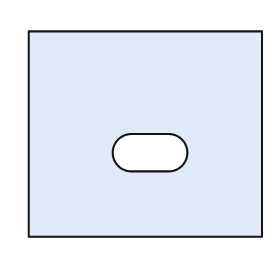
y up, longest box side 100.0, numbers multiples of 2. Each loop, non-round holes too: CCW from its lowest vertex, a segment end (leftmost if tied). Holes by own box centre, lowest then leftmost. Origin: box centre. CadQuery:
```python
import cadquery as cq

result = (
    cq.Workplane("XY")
    .moveTo(-50.0, -44.0)
    .lineTo(50.0, -44.0)
    .lineTo(50.0, 44.0)
    .lineTo(-50.0, 44.0)
    .close()
    .moveTo(-6.0, -16.0)
    .lineTo(10.0, -16.0)
    .threePointArc((18.0, -8.0), (10.0, 0.0))
    .lineTo(-6.0, 0.0)
    .threePointArc((-14.0, -8.0), (-6.0, -16.0))
    .close()
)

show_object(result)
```